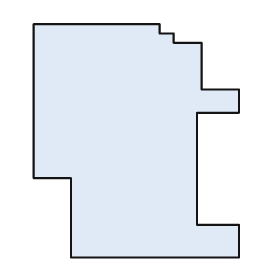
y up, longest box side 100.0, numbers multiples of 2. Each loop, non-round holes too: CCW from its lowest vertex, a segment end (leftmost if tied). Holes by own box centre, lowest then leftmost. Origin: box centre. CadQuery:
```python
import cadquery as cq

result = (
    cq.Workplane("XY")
    .moveTo(-28.0, -50.0)
    .lineTo(44.0, -50.0)
    .lineTo(44.0, -36.0)
    .lineTo(26.0, -36.0)
    .lineTo(26.0, 12.0)
    .lineTo(44.0, 12.0)
    .lineTo(44.0, 22.0)
    .lineTo(28.0, 22.0)
    .lineTo(28.0, 42.0)
    .lineTo(16.0, 42.0)
    .lineTo(16.0, 46.0)
    .lineTo(10.0, 46.0)
    .lineTo(10.0, 50.0)
    .lineTo(-44.0, 50.0)
    .lineTo(-44.0, -16.0)
    .lineTo(-28.0, -16.0)
    .close()
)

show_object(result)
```